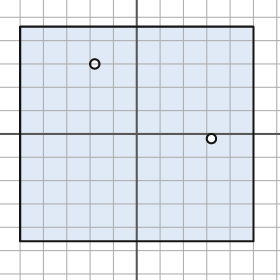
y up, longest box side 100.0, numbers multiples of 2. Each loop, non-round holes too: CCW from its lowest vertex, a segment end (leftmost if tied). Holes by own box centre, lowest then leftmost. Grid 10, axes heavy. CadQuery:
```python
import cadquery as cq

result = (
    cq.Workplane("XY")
    .moveTo(-50.0, -46.0)
    .lineTo(50.0, -46.0)
    .lineTo(50.0, 46.0)
    .lineTo(-50.0, 46.0)
    .close()
    .moveTo(32.0, -2.0)
    .circle(2.0)
    .moveTo(-18.0, 30.0)
    .circle(2.0)
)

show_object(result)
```